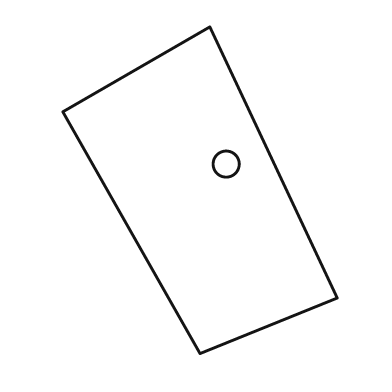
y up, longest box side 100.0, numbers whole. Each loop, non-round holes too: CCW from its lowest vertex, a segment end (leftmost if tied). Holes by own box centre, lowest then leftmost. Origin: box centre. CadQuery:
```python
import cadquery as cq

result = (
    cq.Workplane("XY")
    .moveTo(0.0, -50.0)
    .lineTo(42.0, -33.0)
    .lineTo(3.0, 50.0)
    .lineTo(-42.0, 24.0)
    .close()
    .moveTo(8.0, 8.0)
    .circle(4.0)
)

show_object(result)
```